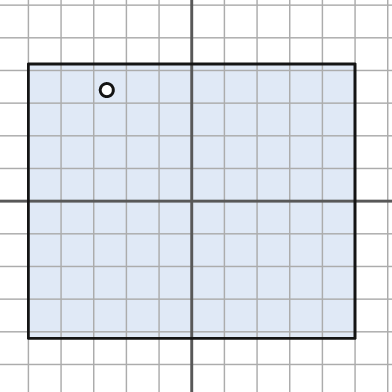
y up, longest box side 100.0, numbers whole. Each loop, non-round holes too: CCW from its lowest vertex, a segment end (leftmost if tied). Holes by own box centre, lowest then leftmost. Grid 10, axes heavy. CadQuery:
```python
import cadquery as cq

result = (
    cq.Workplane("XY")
    .moveTo(-50.0, -42.0)
    .lineTo(50.0, -42.0)
    .lineTo(50.0, 42.0)
    .lineTo(-50.0, 42.0)
    .close()
    .moveTo(-26.0, 34.0)
    .circle(2.0)
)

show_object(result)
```